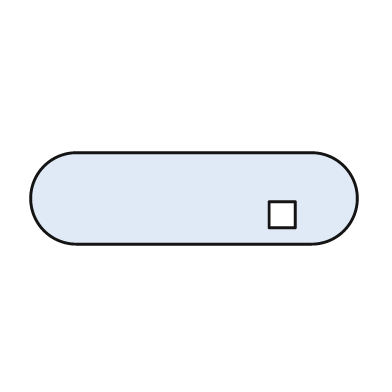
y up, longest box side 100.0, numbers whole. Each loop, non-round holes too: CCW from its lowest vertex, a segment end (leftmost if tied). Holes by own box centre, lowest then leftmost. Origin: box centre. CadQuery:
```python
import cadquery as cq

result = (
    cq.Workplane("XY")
    .moveTo(-36.0, -14.0)
    .lineTo(36.0, -14.0)
    .threePointArc((50.0, 0.0), (36.0, 14.0))
    .lineTo(-36.0, 14.0)
    .threePointArc((-50.0, 0.0), (-36.0, -14.0))
    .close()
    .moveTo(23.0, -9.0)
    .lineTo(31.0, -9.0)
    .lineTo(31.0, -1.0)
    .lineTo(23.0, -1.0)
    .close()
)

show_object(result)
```